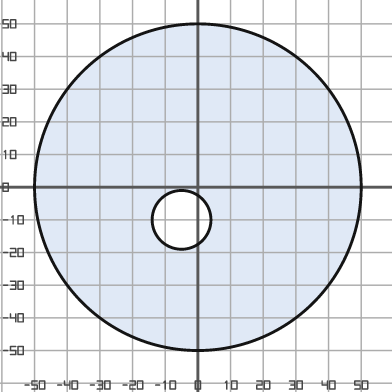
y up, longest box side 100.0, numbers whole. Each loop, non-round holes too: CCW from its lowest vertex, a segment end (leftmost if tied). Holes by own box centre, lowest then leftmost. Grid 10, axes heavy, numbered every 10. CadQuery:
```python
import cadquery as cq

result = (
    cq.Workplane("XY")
    .moveTo(0.0, 0.0)
    .circle(50.0)
    .moveTo(-5.0, -10.0)
    .circle(9.0)
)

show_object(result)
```